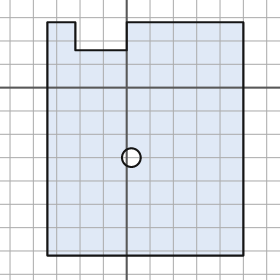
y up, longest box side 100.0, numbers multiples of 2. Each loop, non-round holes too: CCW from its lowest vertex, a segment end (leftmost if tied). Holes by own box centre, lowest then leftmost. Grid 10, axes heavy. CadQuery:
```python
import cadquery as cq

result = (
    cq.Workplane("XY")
    .moveTo(-34.0, -72.0)
    .lineTo(50.0, -72.0)
    .lineTo(50.0, 28.0)
    .lineTo(0.0, 28.0)
    .lineTo(0.0, 16.0)
    .lineTo(-22.0, 16.0)
    .lineTo(-22.0, 28.0)
    .lineTo(-34.0, 28.0)
    .close()
    .moveTo(2.0, -30.0)
    .circle(4.0)
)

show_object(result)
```